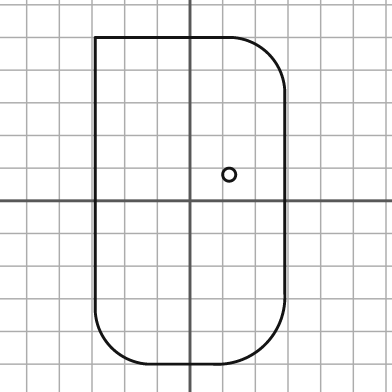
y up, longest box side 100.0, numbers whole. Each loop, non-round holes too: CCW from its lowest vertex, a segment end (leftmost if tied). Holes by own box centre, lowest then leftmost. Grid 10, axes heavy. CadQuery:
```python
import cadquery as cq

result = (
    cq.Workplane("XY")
    .moveTo(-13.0, -50.0)
    .lineTo(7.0, -50.0)
    .threePointArc((23.0, -44.0), (29.0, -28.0))
    .lineTo(29.0, 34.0)
    .threePointArc((24.0, 45.0), (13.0, 50.0))
    .lineTo(-29.0, 50.0)
    .lineTo(-29.0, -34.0)
    .threePointArc((-24.0, -45.0), (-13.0, -50.0))
    .close()
    .moveTo(12.0, 8.0)
    .circle(2.0)
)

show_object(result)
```